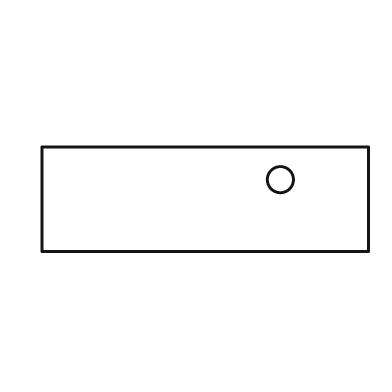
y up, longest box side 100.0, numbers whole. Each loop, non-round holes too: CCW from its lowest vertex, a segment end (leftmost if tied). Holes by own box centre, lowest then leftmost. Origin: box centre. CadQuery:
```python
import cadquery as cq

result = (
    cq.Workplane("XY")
    .moveTo(-50.0, -16.0)
    .lineTo(50.0, -16.0)
    .lineTo(50.0, 16.0)
    .lineTo(-50.0, 16.0)
    .close()
    .moveTo(23.0, 6.0)
    .circle(4.0)
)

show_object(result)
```